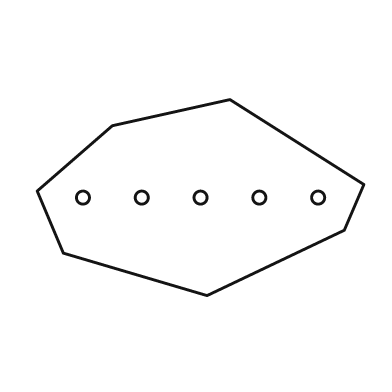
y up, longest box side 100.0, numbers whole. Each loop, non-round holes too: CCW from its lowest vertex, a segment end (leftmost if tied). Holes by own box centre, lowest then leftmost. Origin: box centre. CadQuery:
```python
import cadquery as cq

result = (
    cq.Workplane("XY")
    .moveTo(2.0, -30.0)
    .lineTo(44.0, -10.0)
    .lineTo(50.0, 4.0)
    .lineTo(9.0, 30.0)
    .lineTo(-27.0, 22.0)
    .lineTo(-50.0, 2.0)
    .lineTo(-42.0, -17.0)
    .close()
    .moveTo(-36.0, 0.0)
    .circle(2.0)
    .moveTo(-18.0, 0.0)
    .circle(2.0)
    .moveTo(0.0, 0.0)
    .circle(2.0)
    .moveTo(18.0, 0.0)
    .circle(2.0)
    .moveTo(36.0, 0.0)
    .circle(2.0)
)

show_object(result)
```